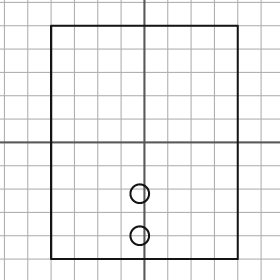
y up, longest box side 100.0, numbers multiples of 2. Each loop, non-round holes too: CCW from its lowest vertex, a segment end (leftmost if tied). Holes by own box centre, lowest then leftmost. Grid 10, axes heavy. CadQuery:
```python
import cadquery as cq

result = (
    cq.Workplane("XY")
    .moveTo(-40.0, -50.0)
    .lineTo(40.0, -50.0)
    .lineTo(40.0, 50.0)
    .lineTo(-40.0, 50.0)
    .close()
    .moveTo(-2.0, -40.0)
    .circle(4.0)
    .moveTo(-2.0, -22.0)
    .circle(4.0)
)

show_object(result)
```